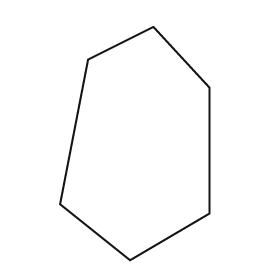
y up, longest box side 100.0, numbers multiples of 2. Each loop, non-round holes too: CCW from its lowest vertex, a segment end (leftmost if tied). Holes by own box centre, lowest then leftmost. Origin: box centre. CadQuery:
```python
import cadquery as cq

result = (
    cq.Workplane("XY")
    .moveTo(-2.0, -50.0)
    .lineTo(32.0, -30.0)
    .lineTo(32.0, 24.0)
    .lineTo(8.0, 50.0)
    .lineTo(-20.0, 36.0)
    .lineTo(-32.0, -26.0)
    .close()
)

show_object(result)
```